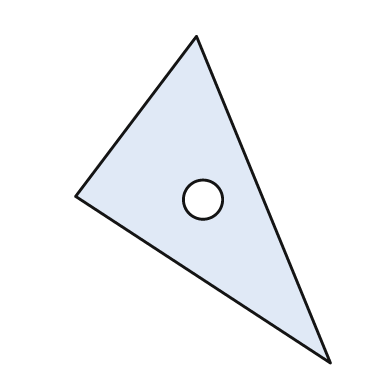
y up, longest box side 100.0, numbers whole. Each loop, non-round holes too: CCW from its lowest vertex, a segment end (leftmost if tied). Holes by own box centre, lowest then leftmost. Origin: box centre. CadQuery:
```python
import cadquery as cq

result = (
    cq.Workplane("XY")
    .moveTo(39.0, -50.0)
    .lineTo(-2.0, 50.0)
    .lineTo(-39.0, 1.0)
    .close()
    .moveTo(0.0, 0.0)
    .circle(6.0)
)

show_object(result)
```